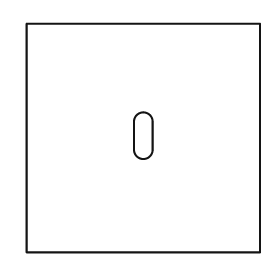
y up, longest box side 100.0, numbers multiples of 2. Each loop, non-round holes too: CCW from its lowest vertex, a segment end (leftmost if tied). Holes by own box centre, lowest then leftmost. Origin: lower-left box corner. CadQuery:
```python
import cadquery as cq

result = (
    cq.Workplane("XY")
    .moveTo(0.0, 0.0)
    .lineTo(100.0, 0.0)
    .lineTo(100.0, 98.0)
    .lineTo(0.0, 98.0)
    .close()
    .moveTo(46.0, 44.0)
    .threePointArc((50.0, 40.0), (54.0, 44.0))
    .lineTo(54.0, 56.0)
    .threePointArc((50.0, 60.0), (46.0, 56.0))
    .close()
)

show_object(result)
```